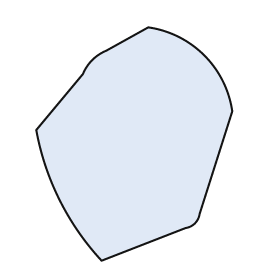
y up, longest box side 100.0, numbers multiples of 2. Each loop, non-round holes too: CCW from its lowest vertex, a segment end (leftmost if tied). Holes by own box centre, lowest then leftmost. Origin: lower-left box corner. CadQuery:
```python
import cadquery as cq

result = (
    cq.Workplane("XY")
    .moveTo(28.0, 0.0)
    .lineTo(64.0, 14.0)
    .threePointArc((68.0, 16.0), (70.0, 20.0))
    .lineTo(84.0, 64.0)
    .threePointArc((72.0, 88.0), (48.0, 100.0))
    .lineTo(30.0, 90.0)
    .threePointArc((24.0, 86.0), (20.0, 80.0))
    .lineTo(0.0, 56.0)
    .threePointArc((10.0, 26.0), (28.0, 0.0))
    .close()
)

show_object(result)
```